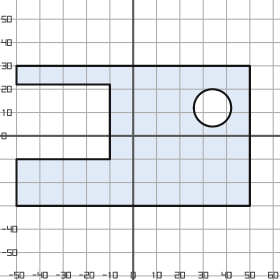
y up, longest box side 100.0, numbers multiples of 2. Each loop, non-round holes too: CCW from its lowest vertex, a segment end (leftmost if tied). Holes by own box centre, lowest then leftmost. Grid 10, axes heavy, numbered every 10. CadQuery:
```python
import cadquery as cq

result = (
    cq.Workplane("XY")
    .moveTo(-50.0, -30.0)
    .lineTo(50.0, -30.0)
    .lineTo(50.0, 30.0)
    .lineTo(-50.0, 30.0)
    .lineTo(-50.0, 22.0)
    .lineTo(-10.0, 22.0)
    .lineTo(-10.0, -10.0)
    .lineTo(-50.0, -10.0)
    .close()
    .moveTo(34.0, 12.0)
    .circle(8.0)
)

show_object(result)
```